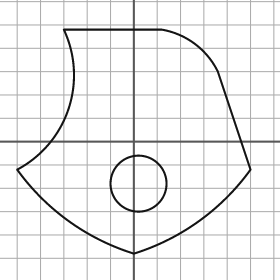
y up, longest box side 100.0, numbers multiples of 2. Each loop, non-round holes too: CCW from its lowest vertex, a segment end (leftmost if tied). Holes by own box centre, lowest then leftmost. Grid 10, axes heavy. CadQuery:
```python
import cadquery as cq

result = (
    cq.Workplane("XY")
    .moveTo(0.0, -48.0)
    .threePointArc((28.0, -34.0), (50.0, -12.0))
    .lineTo(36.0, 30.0)
    .threePointArc((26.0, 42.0), (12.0, 48.0))
    .lineTo(-30.0, 48.0)
    .threePointArc((-28.0, 14.0), (-50.0, -12.0))
    .threePointArc((-28.0, -34.0), (0.0, -48.0))
    .close()
    .moveTo(2.0, -18.0)
    .circle(12.0)
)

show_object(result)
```